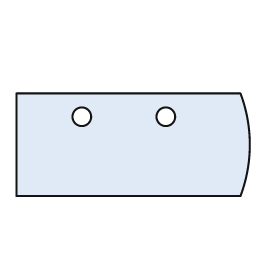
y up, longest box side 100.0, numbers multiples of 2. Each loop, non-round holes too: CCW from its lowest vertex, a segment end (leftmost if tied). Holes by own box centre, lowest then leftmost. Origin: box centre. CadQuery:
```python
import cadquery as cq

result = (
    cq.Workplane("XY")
    .moveTo(-50.0, -22.0)
    .lineTo(46.0, -22.0)
    .threePointArc((50.0, 0.0), (46.0, 22.0))
    .lineTo(-50.0, 22.0)
    .close()
    .moveTo(-22.0, 12.0)
    .circle(4.0)
    .moveTo(14.0, 12.0)
    .circle(4.0)
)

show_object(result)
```